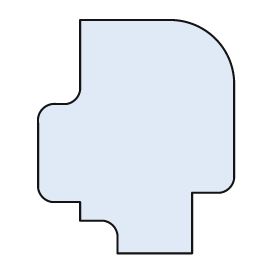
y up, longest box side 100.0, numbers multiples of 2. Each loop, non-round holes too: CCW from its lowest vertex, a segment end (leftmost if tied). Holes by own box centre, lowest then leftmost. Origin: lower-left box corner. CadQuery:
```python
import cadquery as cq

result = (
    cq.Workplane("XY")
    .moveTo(34.0, 0.0)
    .lineTo(66.0, 0.0)
    .lineTo(66.0, 26.0)
    .lineTo(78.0, 26.0)
    .threePointArc((82.0, 28.0), (84.0, 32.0))
    .lineTo(84.0, 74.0)
    .threePointArc((76.0, 92.0), (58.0, 100.0))
    .lineTo(18.0, 100.0)
    .lineTo(18.0, 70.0)
    .threePointArc((16.0, 66.0), (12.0, 64.0))
    .lineTo(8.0, 64.0)
    .threePointArc((2.0, 62.0), (0.0, 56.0))
    .lineTo(0.0, 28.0)
    .threePointArc((2.0, 24.0), (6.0, 22.0))
    .lineTo(18.0, 22.0)
    .lineTo(18.0, 14.0)
    .lineTo(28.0, 14.0)
    .threePointArc((32.0, 12.0), (34.0, 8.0))
    .close()
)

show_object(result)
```